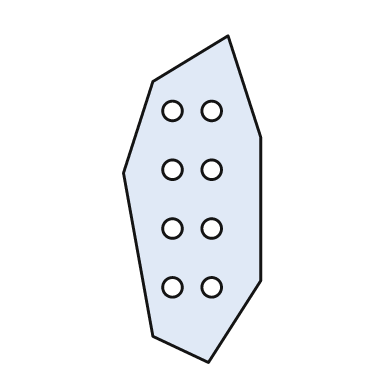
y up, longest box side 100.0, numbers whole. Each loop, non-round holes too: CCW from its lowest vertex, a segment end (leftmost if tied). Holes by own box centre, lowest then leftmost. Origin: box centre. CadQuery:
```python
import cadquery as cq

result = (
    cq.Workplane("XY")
    .moveTo(5.0, -50.0)
    .lineTo(21.0, -25.0)
    .lineTo(21.0, 19.0)
    .lineTo(11.0, 50.0)
    .lineTo(-12.0, 36.0)
    .lineTo(-21.0, 8.0)
    .lineTo(-12.0, -42.0)
    .close()
    .moveTo(-6.0, -27.0)
    .circle(3.0)
    .moveTo(6.0, -27.0)
    .circle(3.0)
    .moveTo(-6.0, -9.0)
    .circle(3.0)
    .moveTo(6.0, -9.0)
    .circle(3.0)
    .moveTo(-6.0, 9.0)
    .circle(3.0)
    .moveTo(6.0, 9.0)
    .circle(3.0)
    .moveTo(-6.0, 27.0)
    .circle(3.0)
    .moveTo(6.0, 27.0)
    .circle(3.0)
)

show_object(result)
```